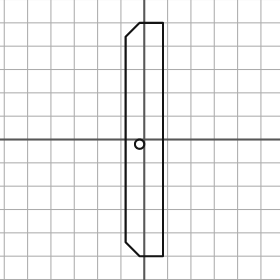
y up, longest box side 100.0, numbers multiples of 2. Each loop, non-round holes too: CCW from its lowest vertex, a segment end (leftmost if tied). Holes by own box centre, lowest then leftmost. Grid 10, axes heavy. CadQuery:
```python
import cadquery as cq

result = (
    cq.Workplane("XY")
    .moveTo(-2.0, -50.0)
    .lineTo(8.0, -50.0)
    .lineTo(8.0, 50.0)
    .lineTo(-2.0, 50.0)
    .lineTo(-8.0, 44.0)
    .lineTo(-8.0, -44.0)
    .close()
    .moveTo(-2.0, -2.0)
    .circle(2.0)
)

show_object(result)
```